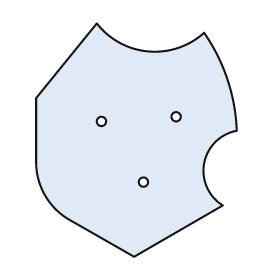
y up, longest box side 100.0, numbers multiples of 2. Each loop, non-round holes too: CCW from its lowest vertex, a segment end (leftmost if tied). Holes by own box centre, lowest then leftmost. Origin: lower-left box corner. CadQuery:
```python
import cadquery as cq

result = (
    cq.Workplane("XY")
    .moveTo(42.0, 0.0)
    .lineTo(80.0, 22.0)
    .threePointArc((72.0, 40.0), (86.0, 54.0))
    .threePointArc((82.0, 76.0), (72.0, 96.0))
    .threePointArc((48.0, 88.0), (26.0, 100.0))
    .lineTo(0.0, 68.0)
    .lineTo(0.0, 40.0)
    .threePointArc((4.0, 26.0), (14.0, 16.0))
    .close()
    .moveTo(46.0, 32.0)
    .circle(2.0)
    .moveTo(28.0, 58.0)
    .circle(2.0)
    .moveTo(60.0, 60.0)
    .circle(2.0)
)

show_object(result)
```